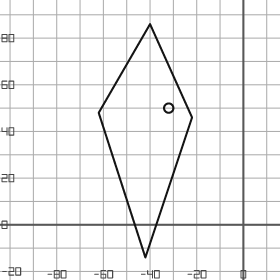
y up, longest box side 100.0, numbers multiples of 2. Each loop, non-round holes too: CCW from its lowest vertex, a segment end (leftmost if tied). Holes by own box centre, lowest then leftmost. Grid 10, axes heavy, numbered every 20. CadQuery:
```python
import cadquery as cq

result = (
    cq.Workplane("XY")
    .moveTo(-42.0, -14.0)
    .lineTo(-22.0, 46.0)
    .lineTo(-40.0, 86.0)
    .lineTo(-62.0, 48.0)
    .close()
    .moveTo(-32.0, 50.0)
    .circle(2.0)
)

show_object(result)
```